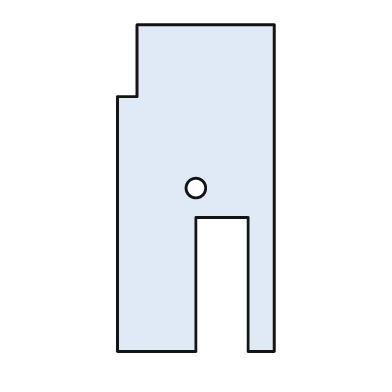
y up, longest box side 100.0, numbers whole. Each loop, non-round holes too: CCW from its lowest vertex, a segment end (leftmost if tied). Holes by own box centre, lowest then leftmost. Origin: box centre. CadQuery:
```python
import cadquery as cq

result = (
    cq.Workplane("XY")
    .moveTo(-24.0, -50.0)
    .lineTo(0.0, -50.0)
    .lineTo(0.0, -9.0)
    .lineTo(16.0, -9.0)
    .lineTo(16.0, -50.0)
    .lineTo(24.0, -50.0)
    .lineTo(24.0, 50.0)
    .lineTo(-18.0, 50.0)
    .lineTo(-18.0, 28.0)
    .lineTo(-24.0, 28.0)
    .close()
    .moveTo(0.0, 0.0)
    .circle(3.0)
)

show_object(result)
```